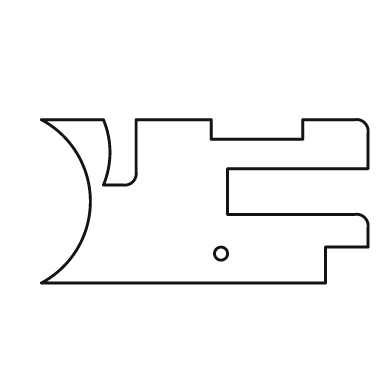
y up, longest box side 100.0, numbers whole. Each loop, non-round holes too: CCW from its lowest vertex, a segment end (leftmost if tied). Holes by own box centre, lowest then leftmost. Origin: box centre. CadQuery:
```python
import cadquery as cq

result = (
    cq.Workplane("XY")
    .moveTo(-50.0, -25.0)
    .lineTo(37.0, -25.0)
    .lineTo(37.0, -14.0)
    .lineTo(50.0, -14.0)
    .lineTo(50.0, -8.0)
    .threePointArc((49.0, -5.0), (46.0, -4.0))
    .lineTo(7.0, -4.0)
    .lineTo(7.0, 10.0)
    .lineTo(50.0, 10.0)
    .lineTo(50.0, 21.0)
    .threePointArc((49.0, 24.0), (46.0, 25.0))
    .lineTo(30.0, 25.0)
    .lineTo(30.0, 19.0)
    .lineTo(2.0, 19.0)
    .lineTo(2.0, 25.0)
    .lineTo(-21.0, 25.0)
    .lineTo(-21.0, 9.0)
    .threePointArc((-22.0, 6.0), (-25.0, 5.0))
    .lineTo(-31.0, 5.0)
    .threePointArc((-29.0, 15.0), (-31.0, 25.0))
    .lineTo(-50.0, 25.0)
    .threePointArc((-35.0, 0.0), (-50.0, -25.0))
    .close()
    .moveTo(5.0, -16.0)
    .circle(2.0)
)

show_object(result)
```